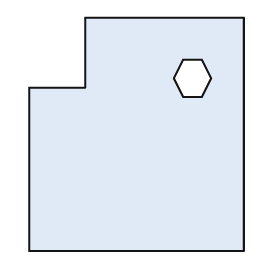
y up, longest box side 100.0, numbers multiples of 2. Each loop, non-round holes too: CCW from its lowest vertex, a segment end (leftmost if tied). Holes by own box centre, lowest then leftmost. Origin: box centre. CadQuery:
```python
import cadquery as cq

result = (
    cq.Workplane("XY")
    .moveTo(-46.0, -50.0)
    .lineTo(46.0, -50.0)
    .lineTo(46.0, 50.0)
    .lineTo(-22.0, 50.0)
    .lineTo(-22.0, 20.0)
    .lineTo(-46.0, 20.0)
    .close()
    .moveTo(20.0, 16.0)
    .lineTo(28.0, 16.0)
    .lineTo(32.0, 24.0)
    .lineTo(28.0, 32.0)
    .lineTo(20.0, 32.0)
    .lineTo(16.0, 24.0)
    .close()
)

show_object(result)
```